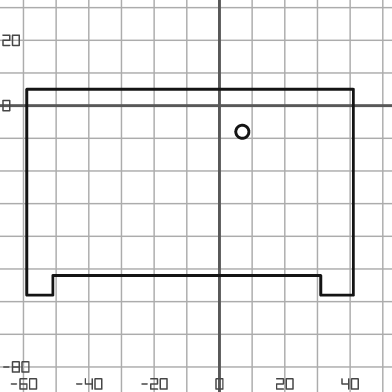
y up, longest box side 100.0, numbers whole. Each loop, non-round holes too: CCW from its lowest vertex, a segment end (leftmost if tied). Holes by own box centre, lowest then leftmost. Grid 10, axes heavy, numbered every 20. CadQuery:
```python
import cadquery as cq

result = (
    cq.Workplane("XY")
    .moveTo(-59.0, -58.0)
    .lineTo(-51.0, -58.0)
    .lineTo(-51.0, -52.0)
    .lineTo(31.0, -52.0)
    .lineTo(31.0, -58.0)
    .lineTo(41.0, -58.0)
    .lineTo(41.0, 5.0)
    .lineTo(-59.0, 5.0)
    .close()
    .moveTo(7.0, -8.0)
    .circle(2.0)
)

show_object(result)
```